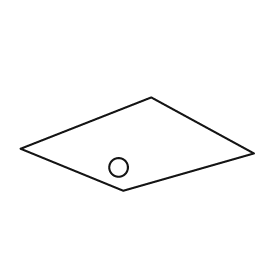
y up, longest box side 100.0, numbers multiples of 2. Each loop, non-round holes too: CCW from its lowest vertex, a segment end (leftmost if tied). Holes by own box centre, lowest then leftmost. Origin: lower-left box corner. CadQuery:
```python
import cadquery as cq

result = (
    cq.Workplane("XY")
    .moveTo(44.0, 0.0)
    .lineTo(100.0, 16.0)
    .lineTo(56.0, 40.0)
    .lineTo(0.0, 18.0)
    .close()
    .moveTo(42.0, 10.0)
    .circle(4.0)
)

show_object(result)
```